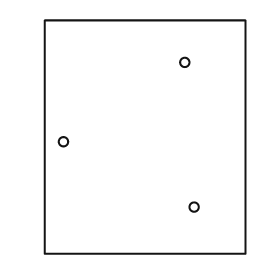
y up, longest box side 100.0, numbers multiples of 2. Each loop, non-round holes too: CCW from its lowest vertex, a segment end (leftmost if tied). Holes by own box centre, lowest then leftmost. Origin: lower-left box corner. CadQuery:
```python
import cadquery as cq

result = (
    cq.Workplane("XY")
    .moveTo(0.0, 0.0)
    .lineTo(86.0, 0.0)
    .lineTo(86.0, 100.0)
    .lineTo(0.0, 100.0)
    .close()
    .moveTo(64.0, 20.0)
    .circle(2.0)
    .moveTo(8.0, 48.0)
    .circle(2.0)
    .moveTo(60.0, 82.0)
    .circle(2.0)
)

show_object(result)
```